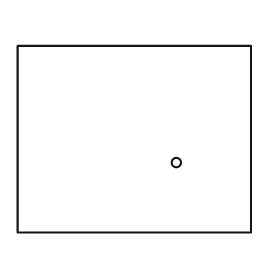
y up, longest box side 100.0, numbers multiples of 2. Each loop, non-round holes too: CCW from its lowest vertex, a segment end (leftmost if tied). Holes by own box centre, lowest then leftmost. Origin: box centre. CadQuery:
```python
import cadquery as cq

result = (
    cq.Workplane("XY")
    .moveTo(-50.0, -40.0)
    .lineTo(50.0, -40.0)
    .lineTo(50.0, 40.0)
    .lineTo(-50.0, 40.0)
    .close()
    .moveTo(18.0, -10.0)
    .circle(2.0)
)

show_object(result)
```